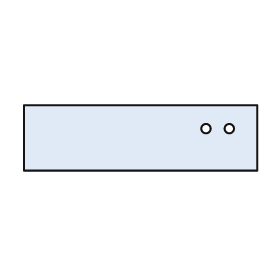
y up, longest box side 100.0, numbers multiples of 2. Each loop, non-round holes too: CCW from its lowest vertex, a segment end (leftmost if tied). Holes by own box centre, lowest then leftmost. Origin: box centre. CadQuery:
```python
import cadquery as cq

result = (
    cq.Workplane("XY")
    .moveTo(-50.0, -14.0)
    .lineTo(50.0, -14.0)
    .lineTo(50.0, 14.0)
    .lineTo(-50.0, 14.0)
    .close()
    .moveTo(28.0, 4.0)
    .circle(2.0)
    .moveTo(38.0, 4.0)
    .circle(2.0)
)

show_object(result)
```